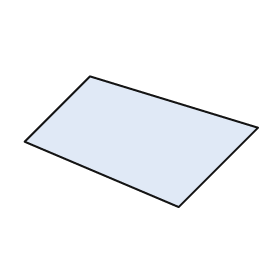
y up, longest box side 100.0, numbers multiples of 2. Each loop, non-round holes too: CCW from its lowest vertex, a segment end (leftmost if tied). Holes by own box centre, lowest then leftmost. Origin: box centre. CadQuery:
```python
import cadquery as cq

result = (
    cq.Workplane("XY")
    .moveTo(16.0, -28.0)
    .lineTo(50.0, 6.0)
    .lineTo(-22.0, 28.0)
    .lineTo(-50.0, 0.0)
    .close()
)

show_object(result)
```